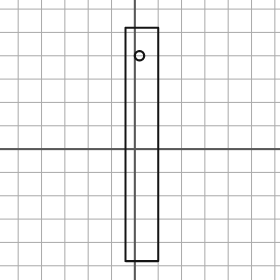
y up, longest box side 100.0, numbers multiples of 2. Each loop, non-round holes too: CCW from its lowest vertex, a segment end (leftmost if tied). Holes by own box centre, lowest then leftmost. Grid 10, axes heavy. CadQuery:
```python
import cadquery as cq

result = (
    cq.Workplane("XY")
    .moveTo(-4.0, -48.0)
    .lineTo(10.0, -48.0)
    .lineTo(10.0, 52.0)
    .lineTo(-4.0, 52.0)
    .close()
    .moveTo(2.0, 40.0)
    .circle(2.0)
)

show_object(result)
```